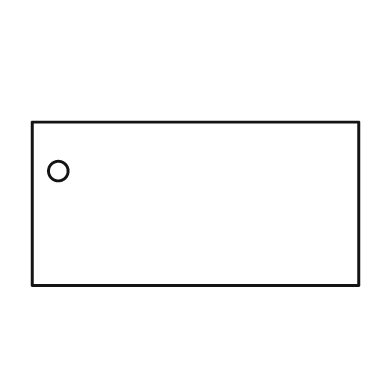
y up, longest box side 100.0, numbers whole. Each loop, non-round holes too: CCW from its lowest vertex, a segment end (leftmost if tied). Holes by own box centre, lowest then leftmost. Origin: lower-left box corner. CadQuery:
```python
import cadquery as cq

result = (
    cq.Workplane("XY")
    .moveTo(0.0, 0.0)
    .lineTo(100.0, 0.0)
    .lineTo(100.0, 50.0)
    .lineTo(0.0, 50.0)
    .close()
    .moveTo(8.0, 35.0)
    .circle(3.0)
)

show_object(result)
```